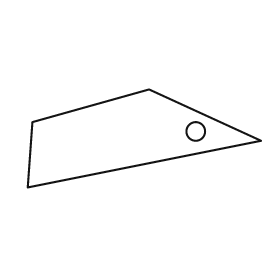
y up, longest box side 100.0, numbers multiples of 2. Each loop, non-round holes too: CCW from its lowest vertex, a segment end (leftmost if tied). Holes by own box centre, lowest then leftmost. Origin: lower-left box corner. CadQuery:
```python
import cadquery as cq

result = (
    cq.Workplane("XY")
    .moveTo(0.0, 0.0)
    .lineTo(100.0, 20.0)
    .lineTo(52.0, 42.0)
    .lineTo(2.0, 28.0)
    .close()
    .moveTo(72.0, 24.0)
    .circle(4.0)
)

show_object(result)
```